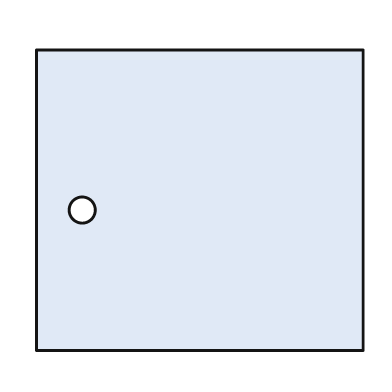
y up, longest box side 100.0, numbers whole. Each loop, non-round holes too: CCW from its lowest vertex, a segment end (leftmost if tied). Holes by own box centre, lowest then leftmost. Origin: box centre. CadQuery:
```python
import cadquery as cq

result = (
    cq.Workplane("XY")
    .moveTo(-50.0, -46.0)
    .lineTo(50.0, -46.0)
    .lineTo(50.0, 46.0)
    .lineTo(-50.0, 46.0)
    .close()
    .moveTo(-36.0, -3.0)
    .circle(4.0)
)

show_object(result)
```